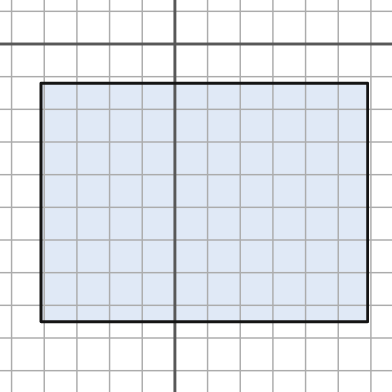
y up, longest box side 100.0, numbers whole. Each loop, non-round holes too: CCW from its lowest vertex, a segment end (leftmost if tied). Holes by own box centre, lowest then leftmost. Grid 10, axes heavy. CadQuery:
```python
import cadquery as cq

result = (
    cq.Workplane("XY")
    .moveTo(-41.0, -85.0)
    .lineTo(59.0, -85.0)
    .lineTo(59.0, -12.0)
    .lineTo(-41.0, -12.0)
    .close()
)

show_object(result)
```